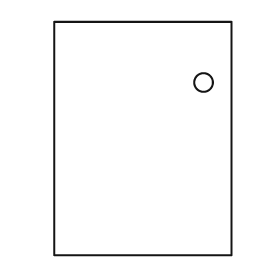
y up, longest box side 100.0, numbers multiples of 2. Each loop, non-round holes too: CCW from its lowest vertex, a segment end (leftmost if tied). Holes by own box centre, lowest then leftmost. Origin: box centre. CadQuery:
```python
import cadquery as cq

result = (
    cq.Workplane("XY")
    .moveTo(-38.0, -50.0)
    .lineTo(38.0, -50.0)
    .lineTo(38.0, 50.0)
    .lineTo(-38.0, 50.0)
    .close()
    .moveTo(26.0, 24.0)
    .circle(4.0)
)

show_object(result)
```